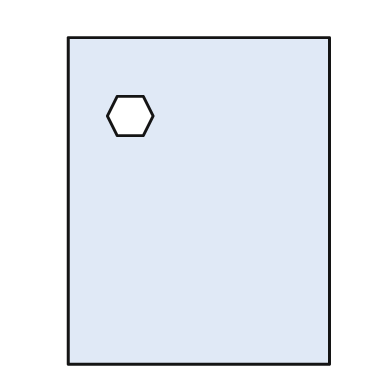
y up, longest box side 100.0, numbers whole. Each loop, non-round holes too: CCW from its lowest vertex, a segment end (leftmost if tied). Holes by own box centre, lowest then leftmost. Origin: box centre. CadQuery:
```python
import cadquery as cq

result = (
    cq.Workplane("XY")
    .moveTo(-40.0, -50.0)
    .lineTo(40.0, -50.0)
    .lineTo(40.0, 50.0)
    .lineTo(-40.0, 50.0)
    .close()
    .moveTo(-25.0, 20.0)
    .lineTo(-17.0, 20.0)
    .lineTo(-14.0, 26.0)
    .lineTo(-17.0, 32.0)
    .lineTo(-25.0, 32.0)
    .lineTo(-28.0, 26.0)
    .close()
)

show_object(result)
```